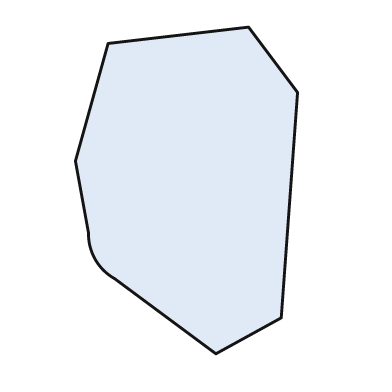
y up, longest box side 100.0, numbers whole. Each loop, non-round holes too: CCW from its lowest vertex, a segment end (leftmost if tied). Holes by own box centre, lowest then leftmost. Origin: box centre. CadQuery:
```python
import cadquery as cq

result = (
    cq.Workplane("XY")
    .moveTo(9.0, -50.0)
    .lineTo(29.0, -39.0)
    .lineTo(34.0, 30.0)
    .lineTo(19.0, 50.0)
    .lineTo(-24.0, 45.0)
    .lineTo(-34.0, 9.0)
    .lineTo(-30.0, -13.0)
    .threePointArc((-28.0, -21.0), (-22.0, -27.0))
    .close()
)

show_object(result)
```